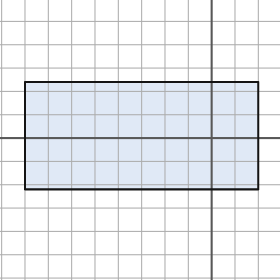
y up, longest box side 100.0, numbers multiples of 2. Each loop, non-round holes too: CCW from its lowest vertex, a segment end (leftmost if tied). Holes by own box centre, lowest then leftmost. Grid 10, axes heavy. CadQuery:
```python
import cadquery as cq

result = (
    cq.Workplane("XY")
    .moveTo(-80.0, -22.0)
    .lineTo(20.0, -22.0)
    .lineTo(20.0, 24.0)
    .lineTo(-80.0, 24.0)
    .close()
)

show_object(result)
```